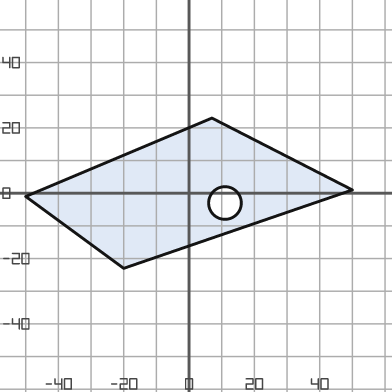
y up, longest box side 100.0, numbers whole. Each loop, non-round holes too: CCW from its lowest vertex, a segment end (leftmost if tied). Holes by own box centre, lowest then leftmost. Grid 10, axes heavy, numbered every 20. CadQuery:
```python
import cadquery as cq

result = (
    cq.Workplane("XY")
    .moveTo(-20.0, -23.0)
    .lineTo(50.0, 1.0)
    .lineTo(7.0, 23.0)
    .lineTo(-50.0, -1.0)
    .close()
    .moveTo(11.0, -3.0)
    .circle(5.0)
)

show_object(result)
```